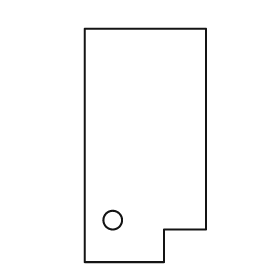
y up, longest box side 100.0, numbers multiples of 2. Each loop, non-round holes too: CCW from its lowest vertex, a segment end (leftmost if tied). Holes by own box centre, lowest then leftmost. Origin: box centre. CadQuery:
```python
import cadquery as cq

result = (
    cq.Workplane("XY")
    .moveTo(-26.0, -50.0)
    .lineTo(8.0, -50.0)
    .lineTo(8.0, -36.0)
    .lineTo(26.0, -36.0)
    .lineTo(26.0, 50.0)
    .lineTo(-26.0, 50.0)
    .close()
    .moveTo(-14.0, -32.0)
    .circle(4.0)
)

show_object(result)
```